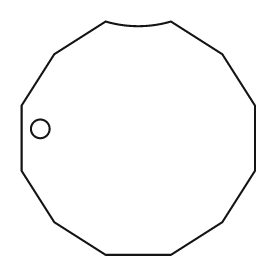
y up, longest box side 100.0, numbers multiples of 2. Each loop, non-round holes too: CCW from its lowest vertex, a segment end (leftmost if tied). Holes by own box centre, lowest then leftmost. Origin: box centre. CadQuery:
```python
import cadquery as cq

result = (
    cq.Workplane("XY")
    .moveTo(-14.0, -50.0)
    .lineTo(14.0, -50.0)
    .lineTo(36.0, -36.0)
    .lineTo(50.0, -14.0)
    .lineTo(50.0, 14.0)
    .lineTo(36.0, 36.0)
    .lineTo(14.0, 50.0)
    .threePointArc((0.0, 48.0), (-14.0, 50.0))
    .lineTo(-36.0, 36.0)
    .lineTo(-50.0, 14.0)
    .lineTo(-50.0, -14.0)
    .lineTo(-36.0, -36.0)
    .close()
    .moveTo(-42.0, 4.0)
    .circle(4.0)
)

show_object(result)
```